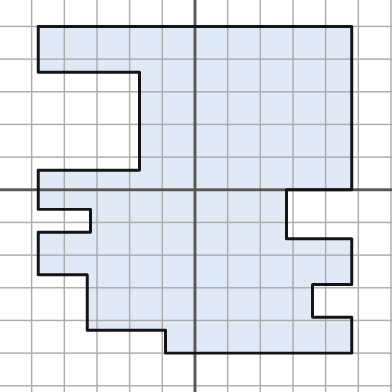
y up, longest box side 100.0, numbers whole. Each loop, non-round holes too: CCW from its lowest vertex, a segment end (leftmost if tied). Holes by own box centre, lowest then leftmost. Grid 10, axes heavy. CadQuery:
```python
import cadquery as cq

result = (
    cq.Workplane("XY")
    .moveTo(-9.0, -50.0)
    .lineTo(48.0, -50.0)
    .lineTo(48.0, -39.0)
    .lineTo(36.0, -39.0)
    .lineTo(36.0, -29.0)
    .lineTo(48.0, -29.0)
    .lineTo(48.0, -15.0)
    .lineTo(28.0, -15.0)
    .lineTo(28.0, 0.0)
    .lineTo(48.0, 0.0)
    .lineTo(48.0, 50.0)
    .lineTo(-48.0, 50.0)
    .lineTo(-48.0, 36.0)
    .lineTo(-17.0, 36.0)
    .lineTo(-17.0, 6.0)
    .lineTo(-48.0, 6.0)
    .lineTo(-48.0, -6.0)
    .lineTo(-32.0, -6.0)
    .lineTo(-32.0, -13.0)
    .lineTo(-48.0, -13.0)
    .lineTo(-48.0, -26.0)
    .lineTo(-33.0, -26.0)
    .lineTo(-33.0, -43.0)
    .lineTo(-9.0, -43.0)
    .close()
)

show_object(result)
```